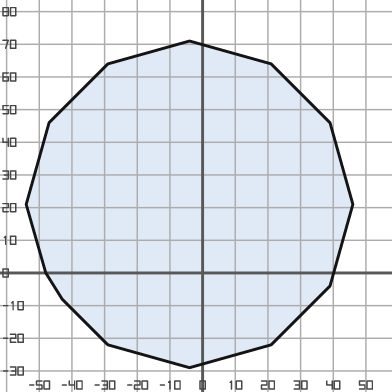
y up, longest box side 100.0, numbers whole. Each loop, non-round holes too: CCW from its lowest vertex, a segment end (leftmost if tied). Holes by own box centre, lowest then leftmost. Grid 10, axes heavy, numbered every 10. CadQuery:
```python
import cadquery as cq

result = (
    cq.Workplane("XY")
    .moveTo(-4.0, -29.0)
    .lineTo(21.0, -22.0)
    .lineTo(39.0, -4.0)
    .lineTo(46.0, 21.0)
    .lineTo(39.0, 46.0)
    .lineTo(21.0, 64.0)
    .lineTo(-4.0, 71.0)
    .lineTo(-29.0, 64.0)
    .lineTo(-47.0, 46.0)
    .lineTo(-54.0, 21.0)
    .lineTo(-48.0, 0.0)
    .lineTo(-43.0, -8.0)
    .lineTo(-29.0, -22.0)
    .close()
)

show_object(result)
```